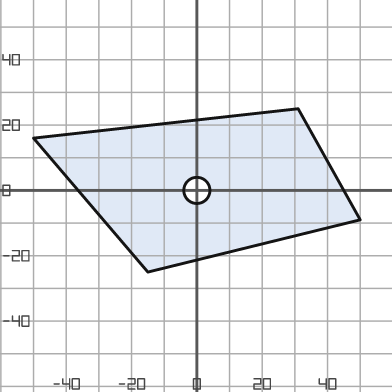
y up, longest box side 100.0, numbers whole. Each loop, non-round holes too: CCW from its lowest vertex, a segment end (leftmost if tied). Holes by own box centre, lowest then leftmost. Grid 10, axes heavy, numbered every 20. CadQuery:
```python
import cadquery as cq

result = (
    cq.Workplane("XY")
    .moveTo(-15.0, -25.0)
    .lineTo(50.0, -9.0)
    .lineTo(31.0, 25.0)
    .lineTo(-50.0, 16.0)
    .close()
    .moveTo(0.0, 0.0)
    .circle(4.0)
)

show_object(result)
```